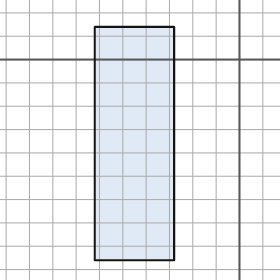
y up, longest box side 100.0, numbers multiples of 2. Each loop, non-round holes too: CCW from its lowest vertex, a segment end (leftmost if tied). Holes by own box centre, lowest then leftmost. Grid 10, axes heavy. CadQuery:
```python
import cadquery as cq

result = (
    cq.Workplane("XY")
    .moveTo(-62.0, -86.0)
    .lineTo(-28.0, -86.0)
    .lineTo(-28.0, 14.0)
    .lineTo(-62.0, 14.0)
    .close()
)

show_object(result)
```